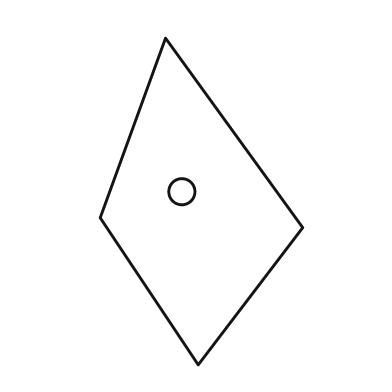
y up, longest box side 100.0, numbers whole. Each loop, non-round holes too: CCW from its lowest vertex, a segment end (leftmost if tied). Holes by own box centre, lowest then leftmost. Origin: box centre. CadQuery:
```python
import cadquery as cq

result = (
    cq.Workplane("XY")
    .moveTo(-1.0, -50.0)
    .lineTo(31.0, -8.0)
    .lineTo(-11.0, 50.0)
    .lineTo(-31.0, -5.0)
    .close()
    .moveTo(-6.0, 3.0)
    .circle(4.0)
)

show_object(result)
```